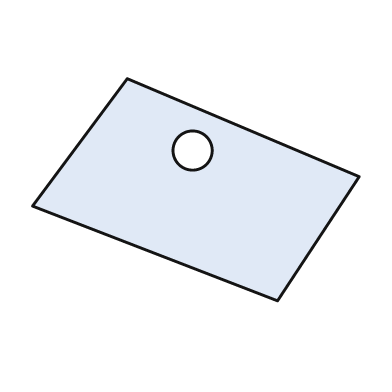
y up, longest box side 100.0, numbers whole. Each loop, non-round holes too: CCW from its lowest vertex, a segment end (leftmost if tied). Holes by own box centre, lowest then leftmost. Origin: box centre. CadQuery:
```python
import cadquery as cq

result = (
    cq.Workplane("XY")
    .moveTo(25.0, -34.0)
    .lineTo(50.0, 4.0)
    .lineTo(-21.0, 34.0)
    .lineTo(-50.0, -5.0)
    .close()
    .moveTo(-1.0, 12.0)
    .circle(6.0)
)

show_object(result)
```